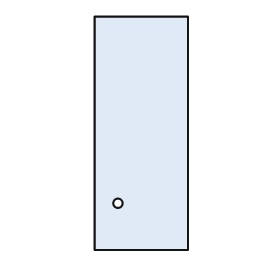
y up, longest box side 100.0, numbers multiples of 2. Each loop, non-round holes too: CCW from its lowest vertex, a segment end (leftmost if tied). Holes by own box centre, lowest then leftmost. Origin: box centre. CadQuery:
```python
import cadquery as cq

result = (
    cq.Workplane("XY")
    .moveTo(-20.0, -50.0)
    .lineTo(20.0, -50.0)
    .lineTo(20.0, 50.0)
    .lineTo(-20.0, 50.0)
    .close()
    .moveTo(-10.0, -30.0)
    .circle(2.0)
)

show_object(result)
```